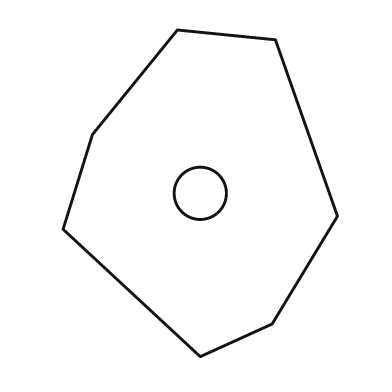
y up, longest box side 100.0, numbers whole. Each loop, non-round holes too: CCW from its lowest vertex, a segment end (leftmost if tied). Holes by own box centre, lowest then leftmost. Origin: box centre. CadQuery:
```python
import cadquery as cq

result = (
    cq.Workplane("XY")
    .moveTo(0.0, -50.0)
    .lineTo(22.0, -40.0)
    .lineTo(42.0, -7.0)
    .lineTo(23.0, 47.0)
    .lineTo(-7.0, 50.0)
    .lineTo(-33.0, 18.0)
    .lineTo(-42.0, -11.0)
    .close()
    .moveTo(0.0, 0.0)
    .circle(8.0)
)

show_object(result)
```